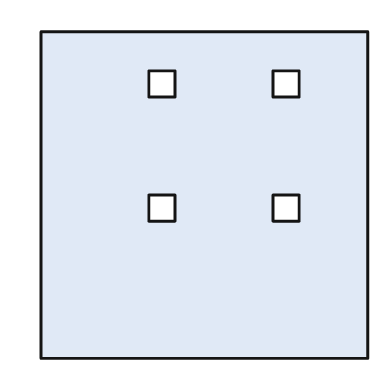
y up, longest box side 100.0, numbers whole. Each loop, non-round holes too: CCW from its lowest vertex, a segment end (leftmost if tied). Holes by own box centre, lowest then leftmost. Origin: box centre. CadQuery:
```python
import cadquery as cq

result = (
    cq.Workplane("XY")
    .moveTo(-50.0, -50.0)
    .lineTo(50.0, -50.0)
    .lineTo(50.0, 50.0)
    .lineTo(-50.0, 50.0)
    .close()
    .moveTo(-17.0, -8.0)
    .lineTo(-9.0, -8.0)
    .lineTo(-9.0, 0.0)
    .lineTo(-17.0, 0.0)
    .close()
    .moveTo(21.0, -8.0)
    .lineTo(29.0, -8.0)
    .lineTo(29.0, 0.0)
    .lineTo(21.0, 0.0)
    .close()
    .moveTo(-17.0, 30.0)
    .lineTo(-9.0, 30.0)
    .lineTo(-9.0, 38.0)
    .lineTo(-17.0, 38.0)
    .close()
    .moveTo(21.0, 30.0)
    .lineTo(29.0, 30.0)
    .lineTo(29.0, 38.0)
    .lineTo(21.0, 38.0)
    .close()
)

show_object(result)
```